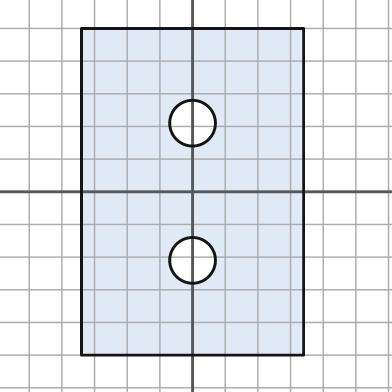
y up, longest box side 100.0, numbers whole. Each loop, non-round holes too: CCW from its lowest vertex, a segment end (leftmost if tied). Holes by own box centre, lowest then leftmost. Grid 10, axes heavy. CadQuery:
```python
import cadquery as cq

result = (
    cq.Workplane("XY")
    .moveTo(-34.0, -50.0)
    .lineTo(34.0, -50.0)
    .lineTo(34.0, 50.0)
    .lineTo(-34.0, 50.0)
    .close()
    .moveTo(0.0, -21.0)
    .circle(7.0)
    .moveTo(0.0, 21.0)
    .circle(7.0)
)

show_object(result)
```